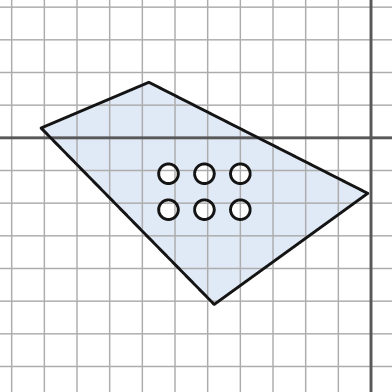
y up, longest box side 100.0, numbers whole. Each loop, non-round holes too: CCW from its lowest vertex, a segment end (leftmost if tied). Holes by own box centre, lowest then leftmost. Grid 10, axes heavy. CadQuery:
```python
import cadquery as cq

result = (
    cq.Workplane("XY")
    .moveTo(-48.0, -51.0)
    .lineTo(-1.0, -17.0)
    .lineTo(-68.0, 17.0)
    .lineTo(-101.0, 3.0)
    .close()
    .moveTo(-62.0, -22.0)
    .circle(3.0)
    .moveTo(-51.0, -22.0)
    .circle(3.0)
    .moveTo(-40.0, -22.0)
    .circle(3.0)
    .moveTo(-62.0, -11.0)
    .circle(3.0)
    .moveTo(-51.0, -11.0)
    .circle(3.0)
    .moveTo(-40.0, -11.0)
    .circle(3.0)
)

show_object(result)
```